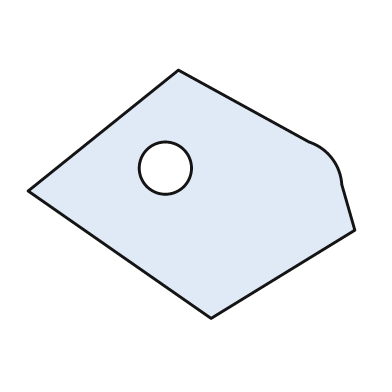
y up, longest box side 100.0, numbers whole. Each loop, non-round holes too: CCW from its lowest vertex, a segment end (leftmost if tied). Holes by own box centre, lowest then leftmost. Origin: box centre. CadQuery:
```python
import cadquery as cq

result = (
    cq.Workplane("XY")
    .moveTo(6.0, -38.0)
    .lineTo(50.0, -11.0)
    .lineTo(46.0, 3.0)
    .threePointArc((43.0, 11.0), (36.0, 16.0))
    .lineTo(-4.0, 38.0)
    .lineTo(-50.0, 1.0)
    .close()
    .moveTo(-8.0, 8.0)
    .circle(8.0)
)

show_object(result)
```